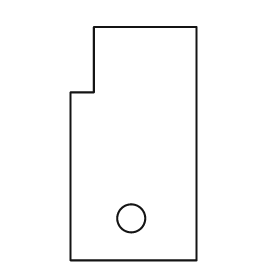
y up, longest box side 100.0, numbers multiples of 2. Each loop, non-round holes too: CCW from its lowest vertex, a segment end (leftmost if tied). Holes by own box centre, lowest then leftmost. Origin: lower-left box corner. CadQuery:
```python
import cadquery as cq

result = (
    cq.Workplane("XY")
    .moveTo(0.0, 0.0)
    .lineTo(54.0, 0.0)
    .lineTo(54.0, 100.0)
    .lineTo(10.0, 100.0)
    .lineTo(10.0, 72.0)
    .lineTo(0.0, 72.0)
    .close()
    .moveTo(26.0, 18.0)
    .circle(6.0)
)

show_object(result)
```